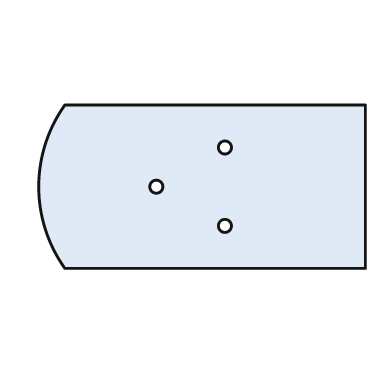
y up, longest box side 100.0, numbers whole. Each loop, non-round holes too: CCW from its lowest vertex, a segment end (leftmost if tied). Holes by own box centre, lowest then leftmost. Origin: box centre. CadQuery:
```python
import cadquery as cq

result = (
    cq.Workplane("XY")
    .moveTo(-42.0, -25.0)
    .lineTo(50.0, -25.0)
    .lineTo(50.0, 25.0)
    .lineTo(-42.0, 25.0)
    .threePointArc((-50.0, 0.0), (-42.0, -25.0))
    .close()
    .moveTo(7.0, -12.0)
    .circle(2.0)
    .moveTo(-14.0, 0.0)
    .circle(2.0)
    .moveTo(7.0, 12.0)
    .circle(2.0)
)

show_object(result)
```